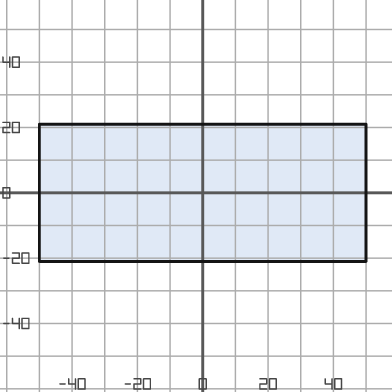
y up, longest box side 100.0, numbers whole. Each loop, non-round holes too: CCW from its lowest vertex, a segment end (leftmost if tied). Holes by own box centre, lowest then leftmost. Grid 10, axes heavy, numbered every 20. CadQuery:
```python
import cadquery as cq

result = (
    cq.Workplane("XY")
    .moveTo(-50.0, -21.0)
    .lineTo(50.0, -21.0)
    .lineTo(50.0, 21.0)
    .lineTo(-50.0, 21.0)
    .close()
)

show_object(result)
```